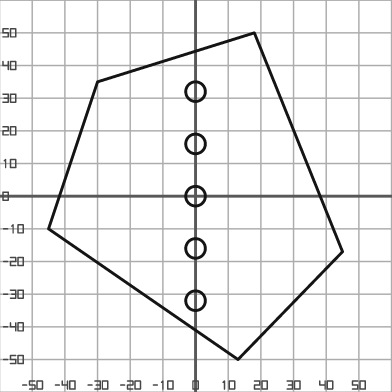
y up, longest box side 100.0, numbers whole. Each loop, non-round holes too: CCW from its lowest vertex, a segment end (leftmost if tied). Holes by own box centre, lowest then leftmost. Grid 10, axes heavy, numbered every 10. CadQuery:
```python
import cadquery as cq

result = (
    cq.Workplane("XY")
    .moveTo(13.0, -50.0)
    .lineTo(45.0, -17.0)
    .lineTo(18.0, 50.0)
    .lineTo(-30.0, 35.0)
    .lineTo(-45.0, -10.0)
    .close()
    .moveTo(0.0, -32.0)
    .circle(3.0)
    .moveTo(0.0, -16.0)
    .circle(3.0)
    .moveTo(0.0, 0.0)
    .circle(3.0)
    .moveTo(0.0, 16.0)
    .circle(3.0)
    .moveTo(0.0, 32.0)
    .circle(3.0)
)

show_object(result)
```